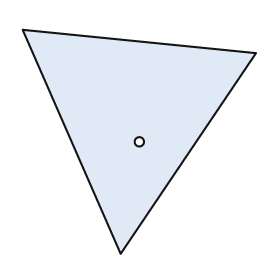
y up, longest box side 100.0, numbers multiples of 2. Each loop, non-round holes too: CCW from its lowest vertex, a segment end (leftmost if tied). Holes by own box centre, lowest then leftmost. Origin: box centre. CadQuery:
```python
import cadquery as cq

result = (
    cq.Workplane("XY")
    .moveTo(-8.0, -48.0)
    .lineTo(50.0, 38.0)
    .lineTo(-50.0, 48.0)
    .close()
    .moveTo(0.0, 0.0)
    .circle(2.0)
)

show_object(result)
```